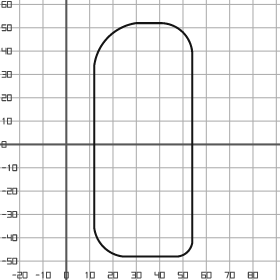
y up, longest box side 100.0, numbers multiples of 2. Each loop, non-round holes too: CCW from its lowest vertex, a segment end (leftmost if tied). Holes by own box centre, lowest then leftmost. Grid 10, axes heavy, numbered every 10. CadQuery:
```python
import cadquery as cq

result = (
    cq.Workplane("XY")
    .moveTo(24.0, -48.0)
    .lineTo(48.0, -48.0)
    .threePointArc((52.0, -46.0), (54.0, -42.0))
    .lineTo(54.0, 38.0)
    .threePointArc((50.0, 48.0), (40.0, 52.0))
    .lineTo(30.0, 52.0)
    .threePointArc((18.0, 46.0), (12.0, 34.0))
    .lineTo(12.0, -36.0)
    .threePointArc((16.0, -44.0), (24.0, -48.0))
    .close()
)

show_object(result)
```